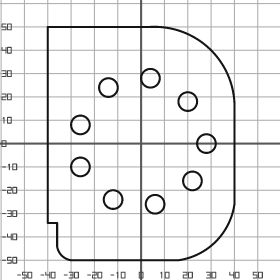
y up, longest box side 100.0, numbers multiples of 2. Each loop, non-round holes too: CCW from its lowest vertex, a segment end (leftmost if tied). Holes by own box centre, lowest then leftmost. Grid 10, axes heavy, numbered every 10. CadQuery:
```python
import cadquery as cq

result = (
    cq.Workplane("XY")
    .moveTo(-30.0, -50.0)
    .lineTo(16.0, -50.0)
    .threePointArc((32.0, -42.0), (40.0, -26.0))
    .lineTo(40.0, 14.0)
    .threePointArc((30.0, 40.0), (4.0, 50.0))
    .lineTo(-40.0, 50.0)
    .lineTo(-40.0, -34.0)
    .lineTo(-36.0, -34.0)
    .lineTo(-36.0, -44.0)
    .threePointArc((-34.0, -48.0), (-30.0, -50.0))
    .close()
    .moveTo(6.0, -26.0)
    .circle(4.0)
    .moveTo(-12.0, -24.0)
    .circle(4.0)
    .moveTo(22.0, -16.0)
    .circle(4.0)
    .moveTo(-26.0, -10.0)
    .circle(4.0)
    .moveTo(28.0, 0.0)
    .circle(4.0)
    .moveTo(-26.0, 8.0)
    .circle(4.0)
    .moveTo(20.0, 18.0)
    .circle(4.0)
    .moveTo(-14.0, 24.0)
    .circle(4.0)
    .moveTo(4.0, 28.0)
    .circle(4.0)
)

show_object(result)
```